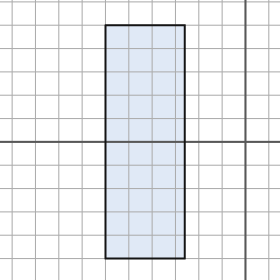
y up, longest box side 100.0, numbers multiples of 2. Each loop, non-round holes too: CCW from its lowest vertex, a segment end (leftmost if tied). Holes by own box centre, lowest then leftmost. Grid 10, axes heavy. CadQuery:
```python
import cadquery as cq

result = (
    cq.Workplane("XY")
    .moveTo(-60.0, -50.0)
    .lineTo(-26.0, -50.0)
    .lineTo(-26.0, 50.0)
    .lineTo(-60.0, 50.0)
    .close()
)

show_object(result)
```